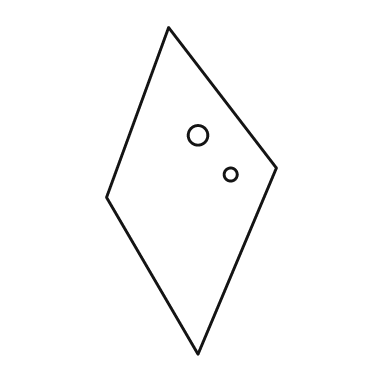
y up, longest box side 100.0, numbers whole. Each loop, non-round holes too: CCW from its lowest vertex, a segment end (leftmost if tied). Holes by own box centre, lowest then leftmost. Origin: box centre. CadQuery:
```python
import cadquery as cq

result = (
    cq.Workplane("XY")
    .moveTo(2.0, -50.0)
    .lineTo(26.0, 7.0)
    .lineTo(-7.0, 50.0)
    .lineTo(-26.0, -2.0)
    .close()
    .moveTo(12.0, 5.0)
    .circle(2.0)
    .moveTo(2.0, 17.0)
    .circle(3.0)
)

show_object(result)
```